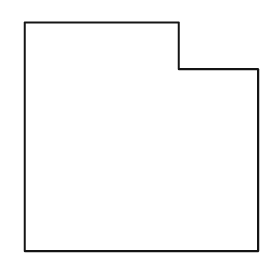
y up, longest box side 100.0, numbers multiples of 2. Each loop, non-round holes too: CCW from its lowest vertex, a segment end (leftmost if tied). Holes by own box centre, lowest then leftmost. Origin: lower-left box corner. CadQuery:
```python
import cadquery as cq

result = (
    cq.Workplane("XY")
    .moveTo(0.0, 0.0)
    .lineTo(100.0, 0.0)
    .lineTo(100.0, 78.0)
    .lineTo(66.0, 78.0)
    .lineTo(66.0, 98.0)
    .lineTo(0.0, 98.0)
    .close()
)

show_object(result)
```